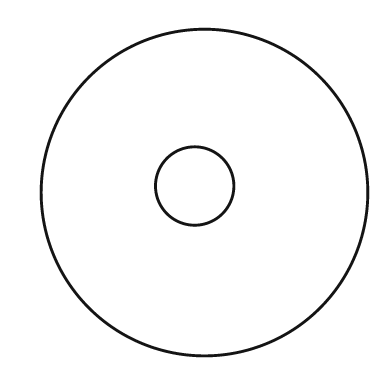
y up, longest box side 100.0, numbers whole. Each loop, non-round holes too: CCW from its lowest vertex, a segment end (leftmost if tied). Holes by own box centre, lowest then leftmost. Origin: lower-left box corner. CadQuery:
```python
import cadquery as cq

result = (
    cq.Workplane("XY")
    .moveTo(50.0, 50.0)
    .circle(50.0)
    .moveTo(47.0, 52.0)
    .circle(12.0)
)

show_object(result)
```